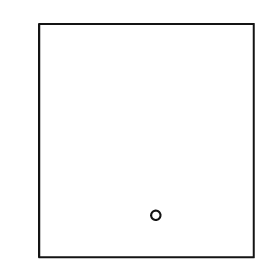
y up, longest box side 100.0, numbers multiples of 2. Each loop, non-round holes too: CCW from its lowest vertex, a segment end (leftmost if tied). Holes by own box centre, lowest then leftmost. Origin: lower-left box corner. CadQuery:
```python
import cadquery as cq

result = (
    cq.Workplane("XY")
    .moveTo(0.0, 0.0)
    .lineTo(92.0, 0.0)
    .lineTo(92.0, 100.0)
    .lineTo(0.0, 100.0)
    .close()
    .moveTo(50.0, 18.0)
    .circle(2.0)
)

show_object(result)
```